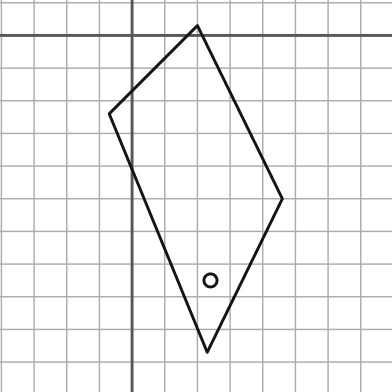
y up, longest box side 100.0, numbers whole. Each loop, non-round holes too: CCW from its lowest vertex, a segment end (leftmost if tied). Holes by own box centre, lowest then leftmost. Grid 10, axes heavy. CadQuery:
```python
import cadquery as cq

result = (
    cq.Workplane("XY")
    .moveTo(23.0, -97.0)
    .lineTo(46.0, -50.0)
    .lineTo(20.0, 3.0)
    .lineTo(-7.0, -24.0)
    .close()
    .moveTo(24.0, -75.0)
    .circle(2.0)
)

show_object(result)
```